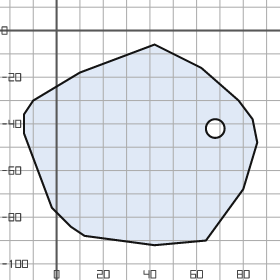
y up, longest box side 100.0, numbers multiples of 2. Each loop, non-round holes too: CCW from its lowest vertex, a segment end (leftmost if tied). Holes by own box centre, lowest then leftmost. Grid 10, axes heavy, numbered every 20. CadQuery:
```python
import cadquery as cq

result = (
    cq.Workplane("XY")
    .moveTo(42.0, -92.0)
    .lineTo(64.0, -90.0)
    .lineTo(80.0, -68.0)
    .lineTo(86.0, -48.0)
    .lineTo(84.0, -38.0)
    .lineTo(78.0, -30.0)
    .lineTo(62.0, -16.0)
    .lineTo(42.0, -6.0)
    .lineTo(10.0, -18.0)
    .lineTo(-10.0, -30.0)
    .lineTo(-14.0, -36.0)
    .lineTo(-14.0, -44.0)
    .lineTo(-2.0, -76.0)
    .lineTo(6.0, -84.0)
    .lineTo(12.0, -88.0)
    .close()
    .moveTo(68.0, -42.0)
    .circle(4.0)
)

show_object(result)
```